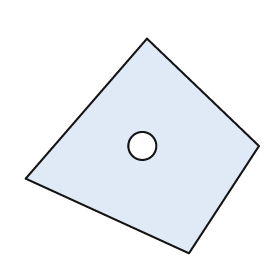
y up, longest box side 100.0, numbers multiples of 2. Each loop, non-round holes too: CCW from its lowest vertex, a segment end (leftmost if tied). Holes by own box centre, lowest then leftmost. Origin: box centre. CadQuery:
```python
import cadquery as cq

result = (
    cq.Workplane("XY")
    .moveTo(20.0, -46.0)
    .lineTo(50.0, 0.0)
    .lineTo(2.0, 46.0)
    .lineTo(-50.0, -14.0)
    .close()
    .moveTo(0.0, 0.0)
    .circle(6.0)
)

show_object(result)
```